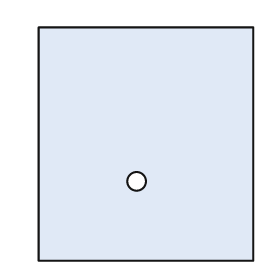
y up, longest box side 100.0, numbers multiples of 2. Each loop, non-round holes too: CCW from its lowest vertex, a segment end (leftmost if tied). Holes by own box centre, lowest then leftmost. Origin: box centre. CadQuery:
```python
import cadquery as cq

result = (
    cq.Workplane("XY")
    .moveTo(-46.0, -50.0)
    .lineTo(46.0, -50.0)
    .lineTo(46.0, 50.0)
    .lineTo(-46.0, 50.0)
    .close()
    .moveTo(-4.0, -16.0)
    .circle(4.0)
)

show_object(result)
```